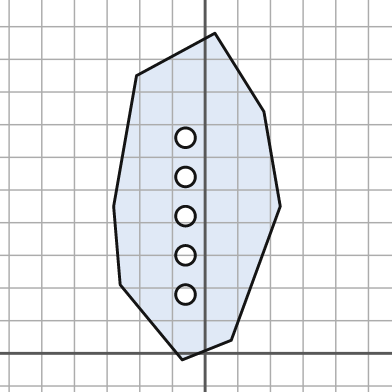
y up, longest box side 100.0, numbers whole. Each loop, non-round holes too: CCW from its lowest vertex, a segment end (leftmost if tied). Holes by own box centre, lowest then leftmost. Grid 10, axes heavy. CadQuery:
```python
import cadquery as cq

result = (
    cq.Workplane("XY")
    .moveTo(-7.0, -2.0)
    .lineTo(8.0, 4.0)
    .lineTo(23.0, 45.0)
    .lineTo(18.0, 74.0)
    .lineTo(3.0, 98.0)
    .lineTo(-21.0, 85.0)
    .lineTo(-28.0, 45.0)
    .lineTo(-26.0, 21.0)
    .close()
    .moveTo(-6.0, 18.0)
    .circle(3.0)
    .moveTo(-6.0, 30.0)
    .circle(3.0)
    .moveTo(-6.0, 42.0)
    .circle(3.0)
    .moveTo(-6.0, 54.0)
    .circle(3.0)
    .moveTo(-6.0, 66.0)
    .circle(3.0)
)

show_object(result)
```